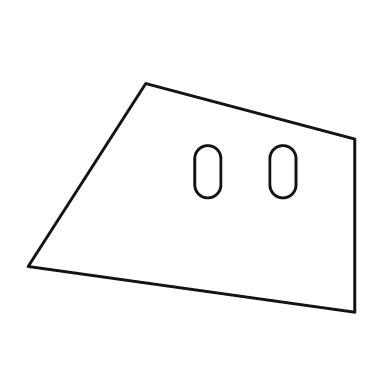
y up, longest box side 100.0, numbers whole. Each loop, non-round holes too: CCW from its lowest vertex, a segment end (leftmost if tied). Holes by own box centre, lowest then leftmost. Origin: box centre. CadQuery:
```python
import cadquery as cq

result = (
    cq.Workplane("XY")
    .moveTo(50.0, -35.0)
    .lineTo(50.0, 18.0)
    .lineTo(-14.0, 35.0)
    .lineTo(-50.0, -21.0)
    .close()
    .moveTo(1.0, 4.0)
    .threePointArc((5.0, 0.0), (9.0, 4.0))
    .lineTo(9.0, 12.0)
    .threePointArc((5.0, 16.0), (1.0, 12.0))
    .close()
    .moveTo(24.0, 4.0)
    .threePointArc((28.0, 0.0), (32.0, 4.0))
    .lineTo(32.0, 12.0)
    .threePointArc((28.0, 16.0), (24.0, 12.0))
    .close()
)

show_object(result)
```